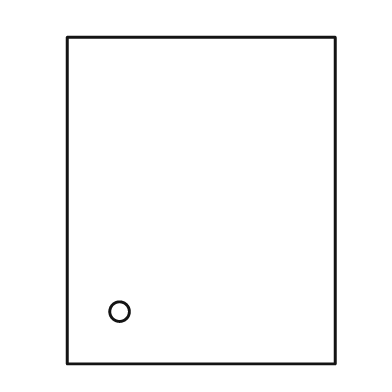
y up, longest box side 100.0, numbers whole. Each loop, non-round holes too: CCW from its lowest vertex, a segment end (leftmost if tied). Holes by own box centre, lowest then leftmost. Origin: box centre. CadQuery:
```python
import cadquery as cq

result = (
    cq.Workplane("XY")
    .moveTo(-41.0, -50.0)
    .lineTo(41.0, -50.0)
    .lineTo(41.0, 50.0)
    .lineTo(-41.0, 50.0)
    .close()
    .moveTo(-25.0, -34.0)
    .circle(3.0)
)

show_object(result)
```